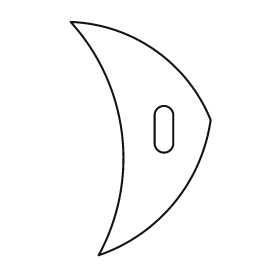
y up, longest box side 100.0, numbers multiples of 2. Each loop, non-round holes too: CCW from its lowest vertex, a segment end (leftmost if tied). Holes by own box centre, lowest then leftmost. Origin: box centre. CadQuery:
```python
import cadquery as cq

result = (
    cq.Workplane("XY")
    .moveTo(-18.0, -50.0)
    .threePointArc((14.0, -28.0), (30.0, 8.0))
    .threePointArc((6.0, 38.0), (-30.0, 50.0))
    .threePointArc((-8.0, 2.0), (-18.0, -50.0))
    .close()
    .moveTo(6.0, -2.0)
    .threePointArc((10.0, -6.0), (14.0, -2.0))
    .lineTo(14.0, 10.0)
    .threePointArc((10.0, 14.0), (6.0, 10.0))
    .close()
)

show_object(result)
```